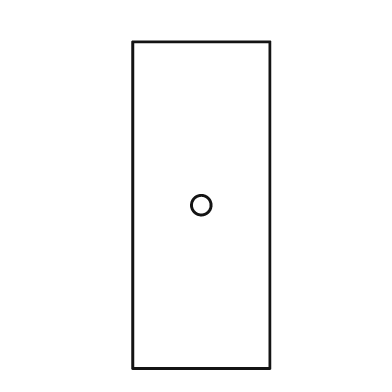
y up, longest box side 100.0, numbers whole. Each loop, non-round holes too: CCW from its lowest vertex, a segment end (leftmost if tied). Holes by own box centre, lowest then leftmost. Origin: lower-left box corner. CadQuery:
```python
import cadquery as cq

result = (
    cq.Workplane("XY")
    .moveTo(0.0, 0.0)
    .lineTo(42.0, 0.0)
    .lineTo(42.0, 100.0)
    .lineTo(0.0, 100.0)
    .close()
    .moveTo(21.0, 50.0)
    .circle(3.0)
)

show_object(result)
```